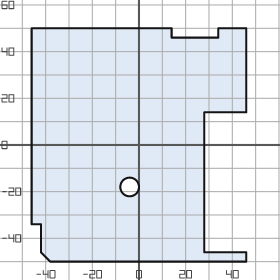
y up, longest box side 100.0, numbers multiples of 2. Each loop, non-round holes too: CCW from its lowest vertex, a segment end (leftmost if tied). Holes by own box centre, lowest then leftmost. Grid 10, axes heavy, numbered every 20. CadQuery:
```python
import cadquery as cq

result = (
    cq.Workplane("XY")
    .moveTo(-38.0, -50.0)
    .lineTo(46.0, -50.0)
    .lineTo(46.0, -46.0)
    .lineTo(28.0, -46.0)
    .lineTo(28.0, 14.0)
    .lineTo(46.0, 14.0)
    .lineTo(46.0, 50.0)
    .lineTo(34.0, 50.0)
    .lineTo(34.0, 46.0)
    .lineTo(14.0, 46.0)
    .lineTo(14.0, 50.0)
    .lineTo(-46.0, 50.0)
    .lineTo(-46.0, -34.0)
    .lineTo(-42.0, -34.0)
    .lineTo(-42.0, -46.0)
    .close()
    .moveTo(-4.0, -18.0)
    .circle(4.0)
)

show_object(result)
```